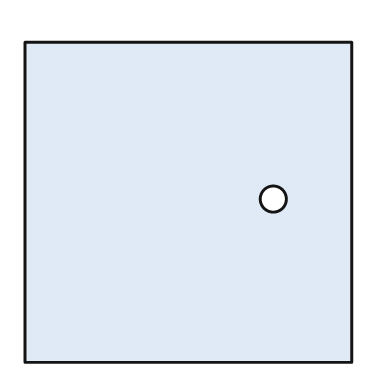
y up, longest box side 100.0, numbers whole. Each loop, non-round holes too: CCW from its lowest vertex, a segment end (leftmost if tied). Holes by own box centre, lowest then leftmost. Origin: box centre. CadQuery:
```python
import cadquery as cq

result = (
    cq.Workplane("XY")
    .moveTo(-50.0, -49.0)
    .lineTo(50.0, -49.0)
    .lineTo(50.0, 49.0)
    .lineTo(-50.0, 49.0)
    .close()
    .moveTo(26.0, 1.0)
    .circle(4.0)
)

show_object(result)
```